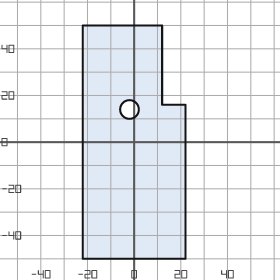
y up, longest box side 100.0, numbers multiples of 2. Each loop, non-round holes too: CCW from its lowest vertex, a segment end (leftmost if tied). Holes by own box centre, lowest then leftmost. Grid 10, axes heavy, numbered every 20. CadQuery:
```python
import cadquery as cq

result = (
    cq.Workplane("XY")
    .moveTo(-22.0, -50.0)
    .lineTo(22.0, -50.0)
    .lineTo(22.0, 16.0)
    .lineTo(12.0, 16.0)
    .lineTo(12.0, 50.0)
    .lineTo(-22.0, 50.0)
    .close()
    .moveTo(-2.0, 14.0)
    .circle(4.0)
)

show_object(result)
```